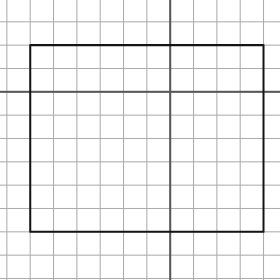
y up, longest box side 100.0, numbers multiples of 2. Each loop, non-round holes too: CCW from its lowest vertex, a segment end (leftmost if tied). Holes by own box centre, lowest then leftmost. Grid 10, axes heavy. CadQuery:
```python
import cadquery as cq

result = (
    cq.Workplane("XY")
    .moveTo(-60.0, -60.0)
    .lineTo(40.0, -60.0)
    .lineTo(40.0, 20.0)
    .lineTo(-60.0, 20.0)
    .close()
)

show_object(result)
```